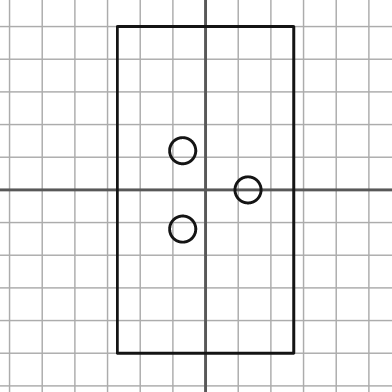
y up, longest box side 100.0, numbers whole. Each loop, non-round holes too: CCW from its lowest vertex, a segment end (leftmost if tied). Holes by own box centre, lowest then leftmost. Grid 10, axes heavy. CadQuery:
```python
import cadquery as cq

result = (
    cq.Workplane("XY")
    .moveTo(-27.0, -50.0)
    .lineTo(27.0, -50.0)
    .lineTo(27.0, 50.0)
    .lineTo(-27.0, 50.0)
    .close()
    .moveTo(-7.0, -12.0)
    .circle(4.0)
    .moveTo(13.0, 0.0)
    .circle(4.0)
    .moveTo(-7.0, 12.0)
    .circle(4.0)
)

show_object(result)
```